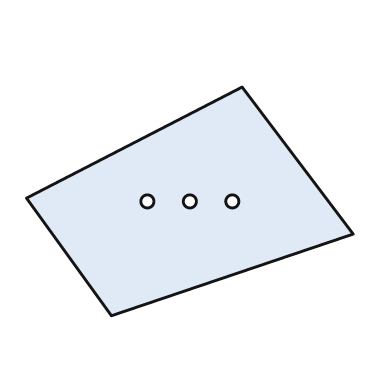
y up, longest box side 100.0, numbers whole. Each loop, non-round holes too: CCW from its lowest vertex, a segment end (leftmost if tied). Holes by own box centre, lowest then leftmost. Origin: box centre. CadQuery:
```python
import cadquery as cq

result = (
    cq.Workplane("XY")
    .moveTo(-24.0, -35.0)
    .lineTo(50.0, -10.0)
    .lineTo(16.0, 35.0)
    .lineTo(-50.0, 1.0)
    .close()
    .moveTo(-13.0, 0.0)
    .circle(2.0)
    .moveTo(0.0, 0.0)
    .circle(2.0)
    .moveTo(13.0, 0.0)
    .circle(2.0)
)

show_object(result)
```